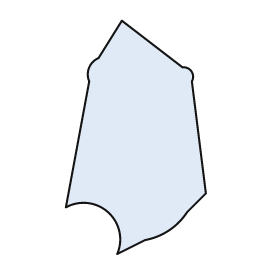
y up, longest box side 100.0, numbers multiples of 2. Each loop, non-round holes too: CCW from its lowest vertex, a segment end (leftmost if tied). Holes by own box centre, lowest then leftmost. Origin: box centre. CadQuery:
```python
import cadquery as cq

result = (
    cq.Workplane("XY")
    .moveTo(-8.0, -50.0)
    .lineTo(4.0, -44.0)
    .threePointArc((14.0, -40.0), (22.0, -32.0))
    .lineTo(30.0, -24.0)
    .lineTo(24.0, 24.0)
    .threePointArc((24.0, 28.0), (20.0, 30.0))
    .lineTo(-6.0, 50.0)
    .lineTo(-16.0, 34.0)
    .threePointArc((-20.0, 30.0), (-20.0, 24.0))
    .lineTo(-30.0, -30.0)
    .threePointArc((-12.0, -32.0), (-8.0, -50.0))
    .close()
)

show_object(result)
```